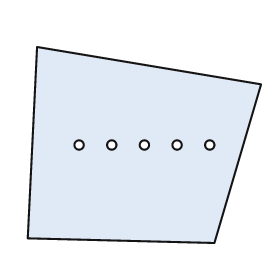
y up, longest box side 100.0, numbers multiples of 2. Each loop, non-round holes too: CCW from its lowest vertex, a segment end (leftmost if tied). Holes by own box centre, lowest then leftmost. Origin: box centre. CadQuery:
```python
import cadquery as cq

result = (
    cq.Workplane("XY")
    .moveTo(30.0, -42.0)
    .lineTo(50.0, 26.0)
    .lineTo(-46.0, 42.0)
    .lineTo(-50.0, -40.0)
    .close()
    .moveTo(-28.0, 0.0)
    .circle(2.0)
    .moveTo(-14.0, 0.0)
    .circle(2.0)
    .moveTo(0.0, 0.0)
    .circle(2.0)
    .moveTo(14.0, 0.0)
    .circle(2.0)
    .moveTo(28.0, 0.0)
    .circle(2.0)
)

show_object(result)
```